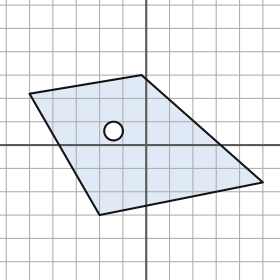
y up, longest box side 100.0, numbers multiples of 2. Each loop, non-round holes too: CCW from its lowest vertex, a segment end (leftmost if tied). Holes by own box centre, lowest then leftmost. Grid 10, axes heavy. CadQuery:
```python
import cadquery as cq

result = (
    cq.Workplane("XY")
    .moveTo(-20.0, -30.0)
    .lineTo(50.0, -16.0)
    .lineTo(-2.0, 30.0)
    .lineTo(-50.0, 22.0)
    .close()
    .moveTo(-14.0, 6.0)
    .circle(4.0)
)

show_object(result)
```